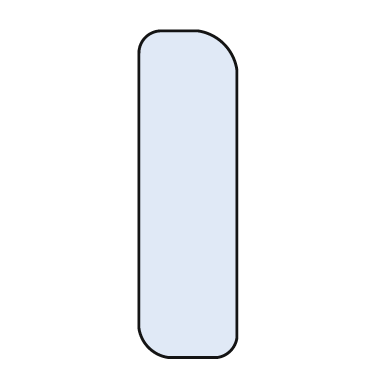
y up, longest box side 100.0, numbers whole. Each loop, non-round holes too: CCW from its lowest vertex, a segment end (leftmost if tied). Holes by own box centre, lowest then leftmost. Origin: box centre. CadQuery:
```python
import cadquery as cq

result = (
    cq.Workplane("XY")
    .moveTo(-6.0, -50.0)
    .lineTo(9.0, -50.0)
    .threePointArc((13.0, -48.0), (15.0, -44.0))
    .lineTo(15.0, 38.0)
    .threePointArc((11.0, 46.0), (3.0, 50.0))
    .lineTo(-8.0, 50.0)
    .threePointArc((-13.0, 48.0), (-15.0, 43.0))
    .lineTo(-15.0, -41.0)
    .threePointArc((-12.0, -47.0), (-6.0, -50.0))
    .close()
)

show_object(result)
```